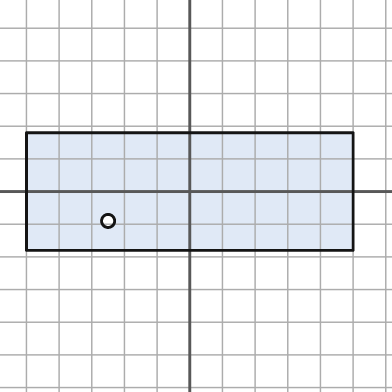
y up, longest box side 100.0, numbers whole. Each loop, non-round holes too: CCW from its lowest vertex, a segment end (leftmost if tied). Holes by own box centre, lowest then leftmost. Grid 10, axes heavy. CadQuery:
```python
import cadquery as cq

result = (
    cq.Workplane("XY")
    .moveTo(-50.0, -18.0)
    .lineTo(50.0, -18.0)
    .lineTo(50.0, 18.0)
    .lineTo(-50.0, 18.0)
    .close()
    .moveTo(-25.0, -9.0)
    .circle(2.0)
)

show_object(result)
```